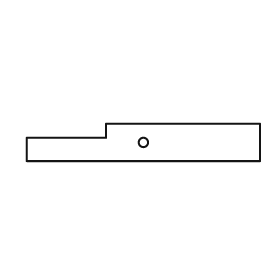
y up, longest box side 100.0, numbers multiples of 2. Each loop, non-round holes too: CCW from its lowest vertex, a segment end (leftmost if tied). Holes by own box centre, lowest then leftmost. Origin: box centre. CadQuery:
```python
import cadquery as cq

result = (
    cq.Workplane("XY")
    .moveTo(-50.0, -8.0)
    .lineTo(50.0, -8.0)
    .lineTo(50.0, 8.0)
    .lineTo(-16.0, 8.0)
    .lineTo(-16.0, 2.0)
    .lineTo(-50.0, 2.0)
    .close()
    .moveTo(0.0, 0.0)
    .circle(2.0)
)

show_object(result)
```